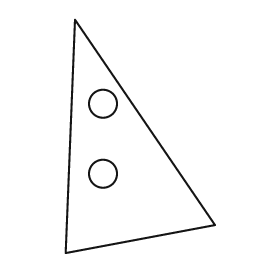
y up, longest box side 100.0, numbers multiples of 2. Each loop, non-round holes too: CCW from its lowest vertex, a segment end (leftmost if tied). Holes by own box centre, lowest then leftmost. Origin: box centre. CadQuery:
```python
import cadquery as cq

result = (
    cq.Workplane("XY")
    .moveTo(-32.0, -50.0)
    .lineTo(32.0, -38.0)
    .lineTo(-28.0, 50.0)
    .close()
    .moveTo(-16.0, -16.0)
    .circle(6.0)
    .moveTo(-16.0, 14.0)
    .circle(6.0)
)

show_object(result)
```